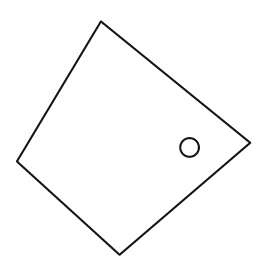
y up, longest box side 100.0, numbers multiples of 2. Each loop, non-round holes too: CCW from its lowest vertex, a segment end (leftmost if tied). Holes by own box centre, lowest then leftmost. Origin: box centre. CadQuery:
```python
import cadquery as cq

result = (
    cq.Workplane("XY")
    .moveTo(-6.0, -50.0)
    .lineTo(50.0, -2.0)
    .lineTo(-14.0, 50.0)
    .lineTo(-50.0, -10.0)
    .close()
    .moveTo(24.0, -4.0)
    .circle(4.0)
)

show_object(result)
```